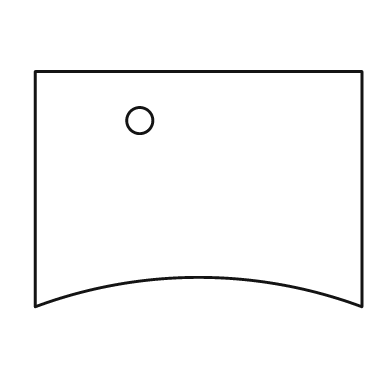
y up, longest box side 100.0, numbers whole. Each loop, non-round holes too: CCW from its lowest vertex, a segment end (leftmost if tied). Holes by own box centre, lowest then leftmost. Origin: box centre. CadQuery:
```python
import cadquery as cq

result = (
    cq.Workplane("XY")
    .moveTo(-50.0, -36.0)
    .threePointArc((0.0, -27.0), (50.0, -36.0))
    .lineTo(50.0, 36.0)
    .lineTo(-50.0, 36.0)
    .close()
    .moveTo(-18.0, 21.0)
    .circle(4.0)
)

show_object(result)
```